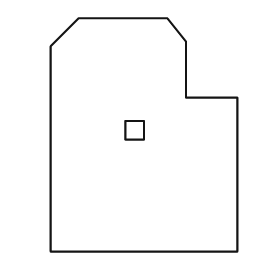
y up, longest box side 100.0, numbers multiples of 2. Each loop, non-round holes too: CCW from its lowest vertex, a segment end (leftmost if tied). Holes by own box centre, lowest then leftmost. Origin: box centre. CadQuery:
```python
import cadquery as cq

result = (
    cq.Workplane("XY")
    .moveTo(-40.0, -50.0)
    .lineTo(40.0, -50.0)
    .lineTo(40.0, 16.0)
    .lineTo(18.0, 16.0)
    .lineTo(18.0, 40.0)
    .lineTo(10.0, 50.0)
    .lineTo(-28.0, 50.0)
    .lineTo(-40.0, 38.0)
    .close()
    .moveTo(-8.0, -2.0)
    .lineTo(0.0, -2.0)
    .lineTo(0.0, 6.0)
    .lineTo(-8.0, 6.0)
    .close()
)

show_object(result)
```